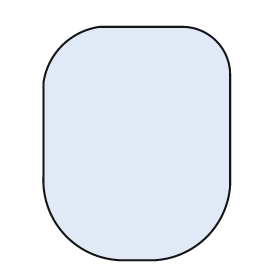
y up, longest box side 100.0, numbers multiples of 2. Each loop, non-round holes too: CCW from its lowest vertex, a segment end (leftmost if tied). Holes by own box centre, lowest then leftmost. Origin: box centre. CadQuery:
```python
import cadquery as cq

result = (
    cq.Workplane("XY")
    .moveTo(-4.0, -50.0)
    .lineTo(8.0, -50.0)
    .threePointArc((30.0, -40.0), (40.0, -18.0))
    .lineTo(40.0, 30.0)
    .threePointArc((34.0, 44.0), (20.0, 50.0))
    .lineTo(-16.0, 50.0)
    .threePointArc((-32.0, 42.0), (-40.0, 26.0))
    .lineTo(-40.0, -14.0)
    .threePointArc((-30.0, -40.0), (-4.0, -50.0))
    .close()
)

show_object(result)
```